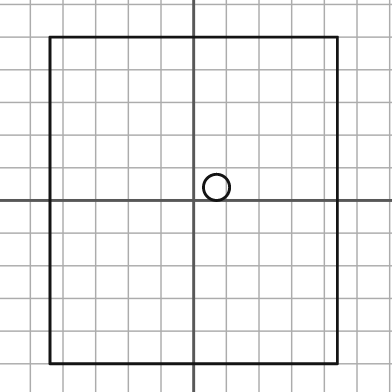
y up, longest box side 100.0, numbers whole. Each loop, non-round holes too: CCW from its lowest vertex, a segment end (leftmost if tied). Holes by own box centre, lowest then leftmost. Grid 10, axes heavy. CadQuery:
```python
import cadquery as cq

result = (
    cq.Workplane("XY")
    .moveTo(-44.0, -50.0)
    .lineTo(44.0, -50.0)
    .lineTo(44.0, 50.0)
    .lineTo(-44.0, 50.0)
    .close()
    .moveTo(7.0, 4.0)
    .circle(4.0)
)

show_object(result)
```